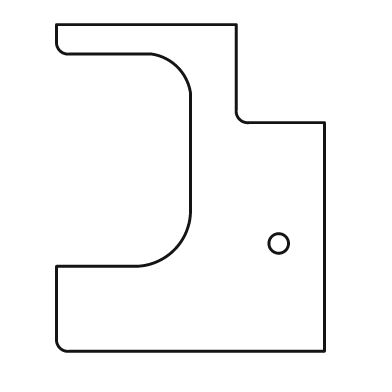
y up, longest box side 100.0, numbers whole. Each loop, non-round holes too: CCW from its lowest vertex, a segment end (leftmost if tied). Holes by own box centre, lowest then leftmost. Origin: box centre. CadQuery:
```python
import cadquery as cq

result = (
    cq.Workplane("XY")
    .moveTo(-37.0, -50.0)
    .lineTo(41.0, -50.0)
    .lineTo(41.0, 20.0)
    .lineTo(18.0, 20.0)
    .threePointArc((15.0, 21.0), (14.0, 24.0))
    .lineTo(14.0, 50.0)
    .lineTo(-41.0, 50.0)
    .lineTo(-41.0, 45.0)
    .threePointArc((-40.0, 42.0), (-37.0, 41.0))
    .lineTo(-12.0, 41.0)
    .threePointArc((-4.0, 37.0), (0.0, 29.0))
    .lineTo(0.0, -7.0)
    .threePointArc((-5.0, -19.0), (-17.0, -24.0))
    .lineTo(-41.0, -24.0)
    .lineTo(-41.0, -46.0)
    .threePointArc((-40.0, -49.0), (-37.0, -50.0))
    .close()
    .moveTo(27.0, -17.0)
    .circle(3.0)
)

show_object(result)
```